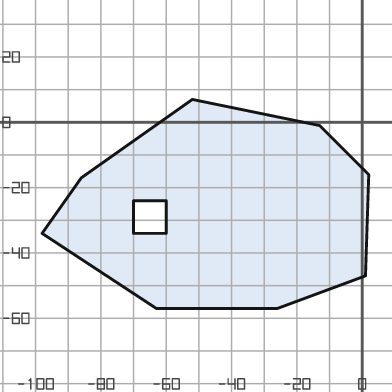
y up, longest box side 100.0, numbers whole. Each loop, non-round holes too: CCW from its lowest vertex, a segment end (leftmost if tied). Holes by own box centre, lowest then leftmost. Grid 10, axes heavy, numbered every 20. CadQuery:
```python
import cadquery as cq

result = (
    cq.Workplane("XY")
    .moveTo(-63.0, -57.0)
    .lineTo(-26.0, -57.0)
    .lineTo(1.0, -47.0)
    .lineTo(2.0, -16.0)
    .lineTo(-13.0, -1.0)
    .lineTo(-52.0, 7.0)
    .lineTo(-86.0, -17.0)
    .lineTo(-98.0, -34.0)
    .close()
    .moveTo(-70.0, -34.0)
    .lineTo(-60.0, -34.0)
    .lineTo(-60.0, -24.0)
    .lineTo(-70.0, -24.0)
    .close()
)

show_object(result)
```